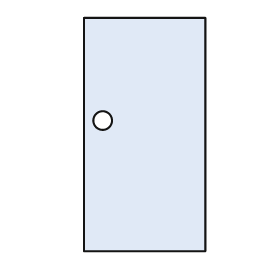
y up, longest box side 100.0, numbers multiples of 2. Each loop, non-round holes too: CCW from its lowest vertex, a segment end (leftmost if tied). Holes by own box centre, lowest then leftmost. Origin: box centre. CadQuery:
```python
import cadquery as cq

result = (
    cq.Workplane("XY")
    .moveTo(-26.0, -50.0)
    .lineTo(26.0, -50.0)
    .lineTo(26.0, 50.0)
    .lineTo(-26.0, 50.0)
    .close()
    .moveTo(-18.0, 6.0)
    .circle(4.0)
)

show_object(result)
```